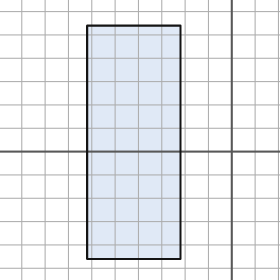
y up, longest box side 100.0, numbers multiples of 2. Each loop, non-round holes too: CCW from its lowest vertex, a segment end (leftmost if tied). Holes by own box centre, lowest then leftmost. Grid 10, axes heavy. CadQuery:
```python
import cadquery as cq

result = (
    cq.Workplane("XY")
    .moveTo(-62.0, -46.0)
    .lineTo(-22.0, -46.0)
    .lineTo(-22.0, 54.0)
    .lineTo(-62.0, 54.0)
    .close()
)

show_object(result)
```